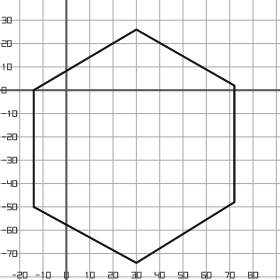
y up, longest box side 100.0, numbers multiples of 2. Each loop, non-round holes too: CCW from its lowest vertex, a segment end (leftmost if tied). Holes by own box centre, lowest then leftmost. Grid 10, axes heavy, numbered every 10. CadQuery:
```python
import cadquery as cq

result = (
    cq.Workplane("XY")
    .moveTo(30.0, -74.0)
    .lineTo(72.0, -48.0)
    .lineTo(72.0, 2.0)
    .lineTo(30.0, 26.0)
    .lineTo(-14.0, 0.0)
    .lineTo(-14.0, -50.0)
    .close()
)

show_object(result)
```